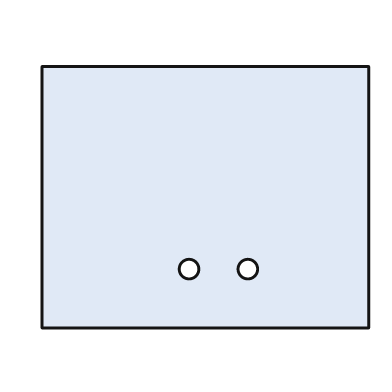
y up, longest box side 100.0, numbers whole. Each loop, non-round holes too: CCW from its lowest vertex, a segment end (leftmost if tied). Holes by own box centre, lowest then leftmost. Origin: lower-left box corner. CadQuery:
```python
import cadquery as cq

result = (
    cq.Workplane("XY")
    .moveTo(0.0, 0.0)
    .lineTo(100.0, 0.0)
    .lineTo(100.0, 80.0)
    .lineTo(0.0, 80.0)
    .close()
    .moveTo(45.0, 18.0)
    .circle(3.0)
    .moveTo(63.0, 18.0)
    .circle(3.0)
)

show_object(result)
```